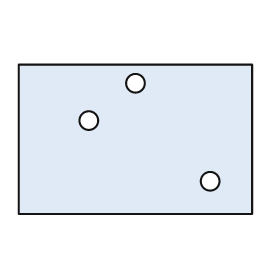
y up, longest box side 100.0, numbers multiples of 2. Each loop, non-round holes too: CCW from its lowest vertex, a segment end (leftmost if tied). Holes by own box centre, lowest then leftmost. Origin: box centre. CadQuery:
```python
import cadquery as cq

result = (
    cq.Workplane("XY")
    .moveTo(-50.0, -32.0)
    .lineTo(50.0, -32.0)
    .lineTo(50.0, 32.0)
    .lineTo(-50.0, 32.0)
    .close()
    .moveTo(32.0, -18.0)
    .circle(4.0)
    .moveTo(-20.0, 8.0)
    .circle(4.0)
    .moveTo(0.0, 24.0)
    .circle(4.0)
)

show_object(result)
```